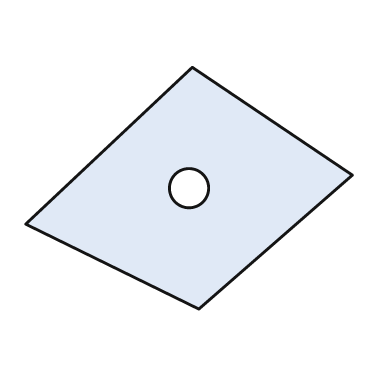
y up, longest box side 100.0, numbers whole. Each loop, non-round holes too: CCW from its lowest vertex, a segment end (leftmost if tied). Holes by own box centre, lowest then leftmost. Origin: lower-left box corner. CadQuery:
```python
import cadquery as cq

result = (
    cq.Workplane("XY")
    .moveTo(53.0, 0.0)
    .lineTo(100.0, 41.0)
    .lineTo(51.0, 74.0)
    .lineTo(0.0, 26.0)
    .close()
    .moveTo(50.0, 37.0)
    .circle(6.0)
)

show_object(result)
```